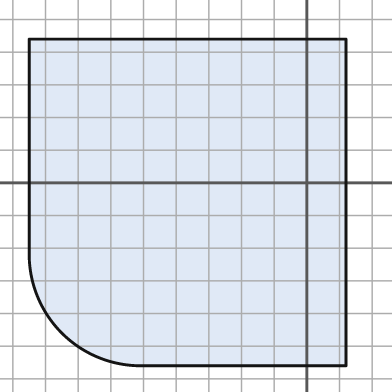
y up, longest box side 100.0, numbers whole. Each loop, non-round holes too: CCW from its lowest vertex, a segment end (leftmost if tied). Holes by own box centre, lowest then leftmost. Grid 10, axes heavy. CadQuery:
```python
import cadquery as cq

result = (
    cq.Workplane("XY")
    .moveTo(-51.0, -56.0)
    .lineTo(12.0, -56.0)
    .lineTo(12.0, 44.0)
    .lineTo(-85.0, 44.0)
    .lineTo(-85.0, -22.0)
    .threePointArc((-75.0, -46.0), (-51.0, -56.0))
    .close()
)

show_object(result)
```